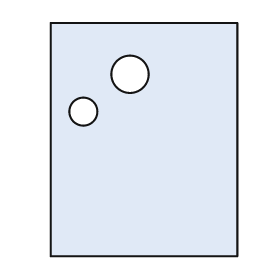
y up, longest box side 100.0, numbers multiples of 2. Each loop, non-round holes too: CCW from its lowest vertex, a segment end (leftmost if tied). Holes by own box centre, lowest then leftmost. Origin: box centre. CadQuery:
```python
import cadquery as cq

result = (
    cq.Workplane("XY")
    .moveTo(-40.0, -50.0)
    .lineTo(40.0, -50.0)
    .lineTo(40.0, 50.0)
    .lineTo(-40.0, 50.0)
    .close()
    .moveTo(-26.0, 12.0)
    .circle(6.0)
    .moveTo(-6.0, 28.0)
    .circle(8.0)
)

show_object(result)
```